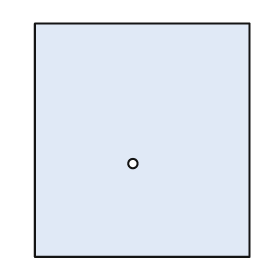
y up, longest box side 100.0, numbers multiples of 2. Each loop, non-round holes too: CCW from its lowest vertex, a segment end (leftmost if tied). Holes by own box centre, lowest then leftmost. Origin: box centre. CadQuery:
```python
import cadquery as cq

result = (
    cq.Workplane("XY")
    .moveTo(-46.0, -50.0)
    .lineTo(46.0, -50.0)
    .lineTo(46.0, 50.0)
    .lineTo(-46.0, 50.0)
    .close()
    .moveTo(-4.0, -10.0)
    .circle(2.0)
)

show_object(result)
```